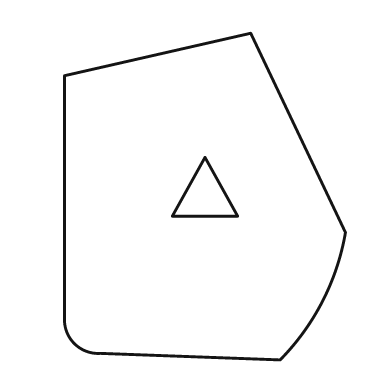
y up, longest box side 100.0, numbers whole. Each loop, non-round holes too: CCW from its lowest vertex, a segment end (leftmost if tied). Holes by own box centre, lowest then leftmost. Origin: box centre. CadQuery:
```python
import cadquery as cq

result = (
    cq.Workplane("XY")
    .moveTo(23.0, -50.0)
    .threePointArc((36.0, -32.0), (43.0, -11.0))
    .lineTo(14.0, 50.0)
    .lineTo(-43.0, 37.0)
    .lineTo(-43.0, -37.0)
    .threePointArc((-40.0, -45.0), (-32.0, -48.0))
    .close()
    .moveTo(-10.0, -6.0)
    .lineTo(10.0, -6.0)
    .lineTo(0.0, 12.0)
    .close()
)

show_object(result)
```